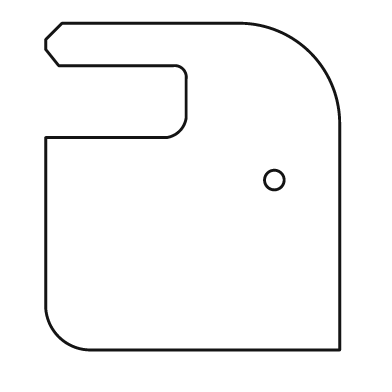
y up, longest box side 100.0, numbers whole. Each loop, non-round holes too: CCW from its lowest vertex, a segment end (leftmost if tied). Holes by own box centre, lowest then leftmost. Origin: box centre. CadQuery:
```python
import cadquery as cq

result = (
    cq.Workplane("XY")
    .moveTo(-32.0, -50.0)
    .lineTo(45.0, -50.0)
    .lineTo(45.0, 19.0)
    .threePointArc((36.0, 41.0), (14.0, 50.0))
    .lineTo(-40.0, 50.0)
    .lineTo(-45.0, 45.0)
    .lineTo(-45.0, 42.0)
    .lineTo(-41.0, 37.0)
    .lineTo(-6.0, 37.0)
    .threePointArc((-3.0, 36.0), (-2.0, 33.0))
    .lineTo(-2.0, 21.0)
    .threePointArc((-4.0, 17.0), (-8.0, 15.0))
    .lineTo(-45.0, 15.0)
    .lineTo(-45.0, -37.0)
    .threePointArc((-41.0, -46.0), (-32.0, -50.0))
    .close()
    .moveTo(25.0, 2.0)
    .circle(3.0)
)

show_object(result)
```